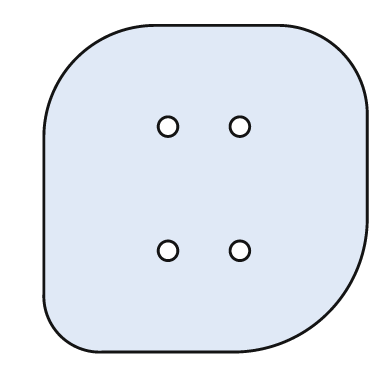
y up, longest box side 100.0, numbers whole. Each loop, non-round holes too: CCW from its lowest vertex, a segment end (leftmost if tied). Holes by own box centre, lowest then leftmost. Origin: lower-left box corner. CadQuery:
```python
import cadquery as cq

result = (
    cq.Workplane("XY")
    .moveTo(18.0, 0.0)
    .lineTo(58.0, 0.0)
    .threePointArc((87.0, 12.0), (99.0, 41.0))
    .lineTo(99.0, 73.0)
    .threePointArc((91.0, 92.0), (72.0, 100.0))
    .lineTo(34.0, 100.0)
    .threePointArc((10.0, 90.0), (0.0, 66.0))
    .lineTo(0.0, 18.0)
    .threePointArc((5.0, 5.0), (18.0, 0.0))
    .close()
    .moveTo(38.0, 31.0)
    .circle(3.0)
    .moveTo(60.0, 31.0)
    .circle(3.0)
    .moveTo(38.0, 69.0)
    .circle(3.0)
    .moveTo(60.0, 69.0)
    .circle(3.0)
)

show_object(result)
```